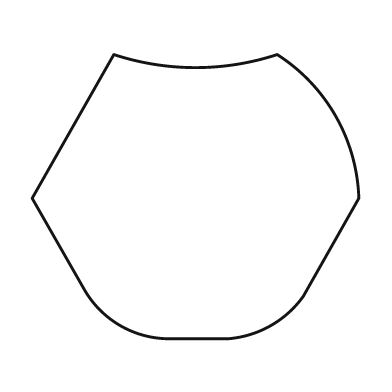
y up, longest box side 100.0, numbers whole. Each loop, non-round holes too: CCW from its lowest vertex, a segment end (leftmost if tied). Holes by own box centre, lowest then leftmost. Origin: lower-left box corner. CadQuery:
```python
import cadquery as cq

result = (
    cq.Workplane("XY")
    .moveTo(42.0, 0.0)
    .lineTo(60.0, 0.0)
    .threePointArc((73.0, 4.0), (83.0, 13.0))
    .lineTo(100.0, 43.0)
    .threePointArc((93.0, 68.0), (75.0, 87.0))
    .threePointArc((50.0, 83.0), (25.0, 87.0))
    .lineTo(0.0, 43.0)
    .lineTo(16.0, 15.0)
    .threePointArc((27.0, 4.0), (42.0, 0.0))
    .close()
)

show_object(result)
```